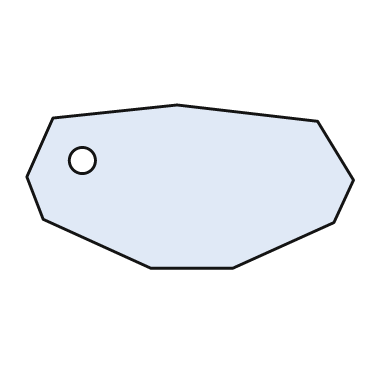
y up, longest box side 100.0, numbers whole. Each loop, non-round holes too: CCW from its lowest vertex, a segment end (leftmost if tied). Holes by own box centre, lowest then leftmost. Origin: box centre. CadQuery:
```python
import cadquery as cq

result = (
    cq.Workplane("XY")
    .moveTo(-12.0, -25.0)
    .lineTo(13.0, -25.0)
    .lineTo(44.0, -11.0)
    .lineTo(50.0, 2.0)
    .lineTo(39.0, 20.0)
    .lineTo(-4.0, 25.0)
    .lineTo(-42.0, 21.0)
    .lineTo(-50.0, 3.0)
    .lineTo(-45.0, -10.0)
    .close()
    .moveTo(-33.0, 8.0)
    .circle(4.0)
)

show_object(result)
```